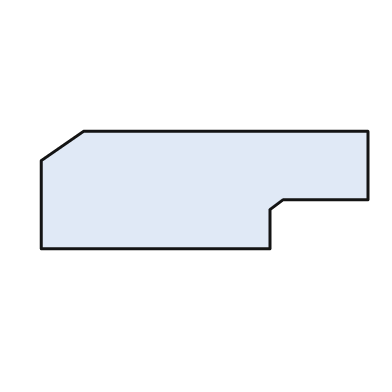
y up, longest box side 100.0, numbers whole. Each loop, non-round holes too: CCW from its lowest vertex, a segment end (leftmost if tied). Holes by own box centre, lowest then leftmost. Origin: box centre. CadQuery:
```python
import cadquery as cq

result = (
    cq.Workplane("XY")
    .moveTo(-50.0, -18.0)
    .lineTo(20.0, -18.0)
    .lineTo(20.0, -6.0)
    .lineTo(24.0, -3.0)
    .lineTo(50.0, -3.0)
    .lineTo(50.0, 18.0)
    .lineTo(-37.0, 18.0)
    .lineTo(-50.0, 9.0)
    .close()
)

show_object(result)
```